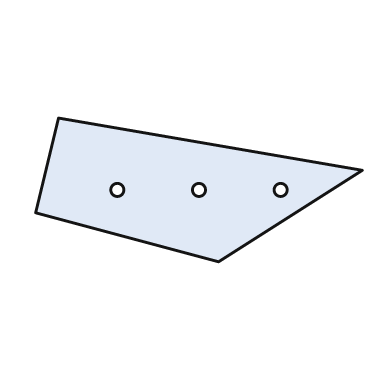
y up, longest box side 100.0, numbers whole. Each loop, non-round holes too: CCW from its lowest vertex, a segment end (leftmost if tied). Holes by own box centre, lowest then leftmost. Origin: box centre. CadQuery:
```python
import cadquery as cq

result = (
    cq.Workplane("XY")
    .moveTo(6.0, -22.0)
    .lineTo(50.0, 6.0)
    .lineTo(-43.0, 22.0)
    .lineTo(-50.0, -7.0)
    .close()
    .moveTo(-25.0, 0.0)
    .circle(2.0)
    .moveTo(0.0, 0.0)
    .circle(2.0)
    .moveTo(25.0, 0.0)
    .circle(2.0)
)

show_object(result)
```